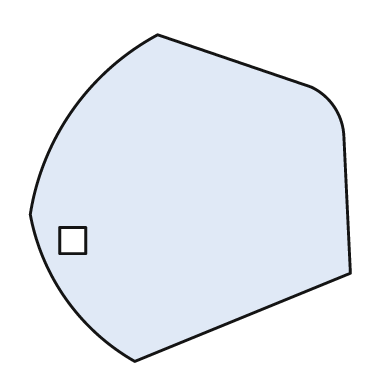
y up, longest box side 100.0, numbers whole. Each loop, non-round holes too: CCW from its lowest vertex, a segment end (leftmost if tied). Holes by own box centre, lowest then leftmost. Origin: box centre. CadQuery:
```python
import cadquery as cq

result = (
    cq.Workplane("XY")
    .moveTo(-17.0, -50.0)
    .lineTo(49.0, -23.0)
    .lineTo(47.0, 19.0)
    .threePointArc((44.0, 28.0), (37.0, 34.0))
    .lineTo(-10.0, 50.0)
    .threePointArc((-36.0, 27.0), (-49.0, -5.0))
    .threePointArc((-38.0, -31.0), (-17.0, -50.0))
    .close()
    .moveTo(-40.0, -17.0)
    .lineTo(-32.0, -17.0)
    .lineTo(-32.0, -9.0)
    .lineTo(-40.0, -9.0)
    .close()
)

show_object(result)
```